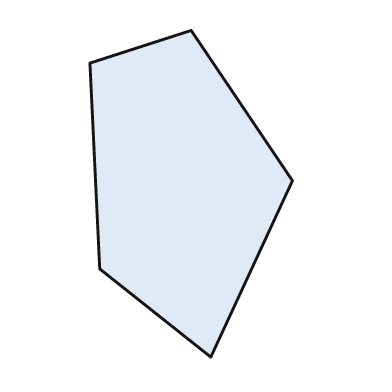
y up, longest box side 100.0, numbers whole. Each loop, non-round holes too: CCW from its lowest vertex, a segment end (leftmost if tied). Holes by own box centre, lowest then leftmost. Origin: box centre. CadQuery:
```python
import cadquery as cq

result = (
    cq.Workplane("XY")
    .moveTo(6.0, -50.0)
    .lineTo(31.0, 4.0)
    .lineTo(0.0, 50.0)
    .lineTo(-31.0, 40.0)
    .lineTo(-28.0, -23.0)
    .close()
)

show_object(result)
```